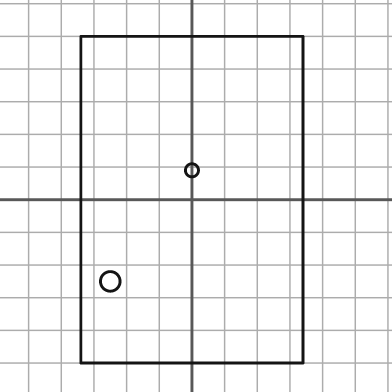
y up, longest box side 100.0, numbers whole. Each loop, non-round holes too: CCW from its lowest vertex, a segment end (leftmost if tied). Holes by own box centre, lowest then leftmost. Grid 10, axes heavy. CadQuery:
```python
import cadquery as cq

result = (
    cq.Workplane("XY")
    .moveTo(-34.0, -50.0)
    .lineTo(34.0, -50.0)
    .lineTo(34.0, 50.0)
    .lineTo(-34.0, 50.0)
    .close()
    .moveTo(-25.0, -25.0)
    .circle(3.0)
    .moveTo(0.0, 9.0)
    .circle(2.0)
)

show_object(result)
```